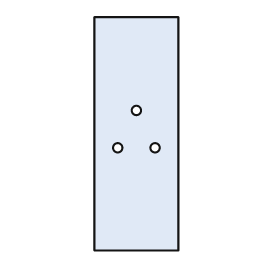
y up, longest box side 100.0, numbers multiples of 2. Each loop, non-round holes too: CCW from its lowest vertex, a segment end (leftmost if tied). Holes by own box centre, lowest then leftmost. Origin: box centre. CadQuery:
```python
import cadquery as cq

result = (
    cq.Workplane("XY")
    .moveTo(-18.0, -50.0)
    .lineTo(18.0, -50.0)
    .lineTo(18.0, 50.0)
    .lineTo(-18.0, 50.0)
    .close()
    .moveTo(-8.0, -6.0)
    .circle(2.0)
    .moveTo(8.0, -6.0)
    .circle(2.0)
    .moveTo(0.0, 10.0)
    .circle(2.0)
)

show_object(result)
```